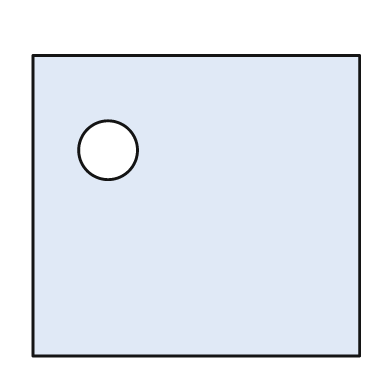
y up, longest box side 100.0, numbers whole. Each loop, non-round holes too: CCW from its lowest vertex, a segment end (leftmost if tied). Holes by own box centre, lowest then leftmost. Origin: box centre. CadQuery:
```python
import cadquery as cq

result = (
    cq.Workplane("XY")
    .moveTo(-50.0, -46.0)
    .lineTo(50.0, -46.0)
    .lineTo(50.0, 46.0)
    .lineTo(-50.0, 46.0)
    .close()
    .moveTo(-27.0, 17.0)
    .circle(9.0)
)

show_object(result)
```